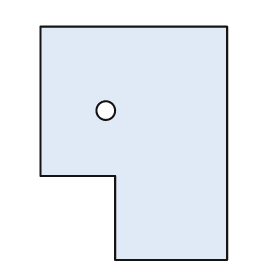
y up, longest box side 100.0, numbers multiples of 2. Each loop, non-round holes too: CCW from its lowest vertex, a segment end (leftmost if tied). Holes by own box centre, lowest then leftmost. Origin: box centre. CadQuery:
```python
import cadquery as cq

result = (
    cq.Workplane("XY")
    .moveTo(-8.0, -50.0)
    .lineTo(40.0, -50.0)
    .lineTo(40.0, 50.0)
    .lineTo(-40.0, 50.0)
    .lineTo(-40.0, -14.0)
    .lineTo(-8.0, -14.0)
    .close()
    .moveTo(-12.0, 14.0)
    .circle(4.0)
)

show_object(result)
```